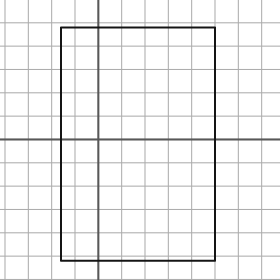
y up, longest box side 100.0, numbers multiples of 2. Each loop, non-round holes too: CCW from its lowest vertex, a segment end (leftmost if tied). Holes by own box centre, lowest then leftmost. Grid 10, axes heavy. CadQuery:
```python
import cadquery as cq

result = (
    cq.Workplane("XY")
    .moveTo(-16.0, -52.0)
    .lineTo(50.0, -52.0)
    .lineTo(50.0, 48.0)
    .lineTo(-16.0, 48.0)
    .close()
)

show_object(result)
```